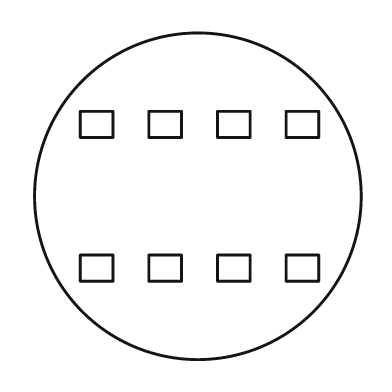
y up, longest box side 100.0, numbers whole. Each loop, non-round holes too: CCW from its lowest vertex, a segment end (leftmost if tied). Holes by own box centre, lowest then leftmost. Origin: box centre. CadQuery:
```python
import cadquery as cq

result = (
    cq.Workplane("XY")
    .moveTo(0.0, 0.0)
    .circle(50.0)
    .moveTo(-36.0, -26.0)
    .lineTo(-26.0, -26.0)
    .lineTo(-26.0, -18.0)
    .lineTo(-36.0, -18.0)
    .close()
    .moveTo(-15.0, -26.0)
    .lineTo(-5.0, -26.0)
    .lineTo(-5.0, -18.0)
    .lineTo(-15.0, -18.0)
    .close()
    .moveTo(6.0, -26.0)
    .lineTo(16.0, -26.0)
    .lineTo(16.0, -18.0)
    .lineTo(6.0, -18.0)
    .close()
    .moveTo(27.0, -26.0)
    .lineTo(37.0, -26.0)
    .lineTo(37.0, -18.0)
    .lineTo(27.0, -18.0)
    .close()
    .moveTo(-36.0, 18.0)
    .lineTo(-26.0, 18.0)
    .lineTo(-26.0, 26.0)
    .lineTo(-36.0, 26.0)
    .close()
    .moveTo(-15.0, 18.0)
    .lineTo(-5.0, 18.0)
    .lineTo(-5.0, 26.0)
    .lineTo(-15.0, 26.0)
    .close()
    .moveTo(6.0, 18.0)
    .lineTo(16.0, 18.0)
    .lineTo(16.0, 26.0)
    .lineTo(6.0, 26.0)
    .close()
    .moveTo(27.0, 18.0)
    .lineTo(37.0, 18.0)
    .lineTo(37.0, 26.0)
    .lineTo(27.0, 26.0)
    .close()
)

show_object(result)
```